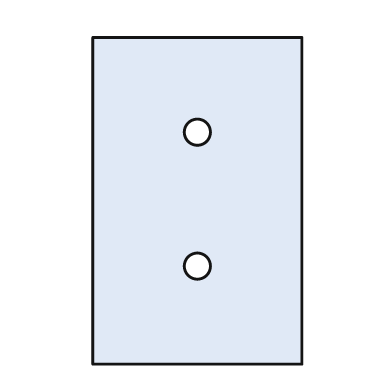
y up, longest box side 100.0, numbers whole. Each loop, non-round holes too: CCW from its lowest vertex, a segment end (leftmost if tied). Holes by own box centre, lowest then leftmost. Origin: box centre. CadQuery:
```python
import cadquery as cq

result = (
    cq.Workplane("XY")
    .moveTo(-32.0, -50.0)
    .lineTo(32.0, -50.0)
    .lineTo(32.0, 50.0)
    .lineTo(-32.0, 50.0)
    .close()
    .moveTo(0.0, -20.0)
    .circle(4.0)
    .moveTo(0.0, 21.0)
    .circle(4.0)
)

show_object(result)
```